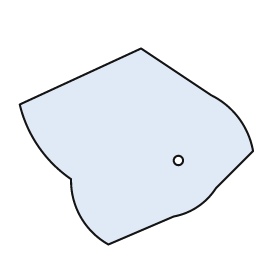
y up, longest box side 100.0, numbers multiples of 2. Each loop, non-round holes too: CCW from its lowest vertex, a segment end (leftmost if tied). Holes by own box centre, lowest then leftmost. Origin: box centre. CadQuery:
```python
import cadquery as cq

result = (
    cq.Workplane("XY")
    .moveTo(-12.0, -42.0)
    .lineTo(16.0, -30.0)
    .threePointArc((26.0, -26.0), (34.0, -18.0))
    .lineTo(50.0, -2.0)
    .threePointArc((44.0, 12.0), (32.0, 22.0))
    .lineTo(2.0, 42.0)
    .lineTo(-50.0, 18.0)
    .threePointArc((-42.0, 0.0), (-28.0, -14.0))
    .threePointArc((-24.0, -30.0), (-12.0, -42.0))
    .close()
    .moveTo(18.0, -6.0)
    .circle(2.0)
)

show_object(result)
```